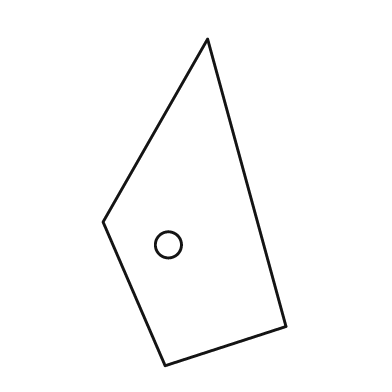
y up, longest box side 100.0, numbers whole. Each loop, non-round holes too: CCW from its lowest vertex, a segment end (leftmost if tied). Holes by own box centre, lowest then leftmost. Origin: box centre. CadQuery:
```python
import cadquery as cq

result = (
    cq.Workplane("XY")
    .moveTo(-9.0, -50.0)
    .lineTo(28.0, -38.0)
    .lineTo(4.0, 50.0)
    .lineTo(-28.0, -6.0)
    .close()
    .moveTo(-8.0, -13.0)
    .circle(4.0)
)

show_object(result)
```